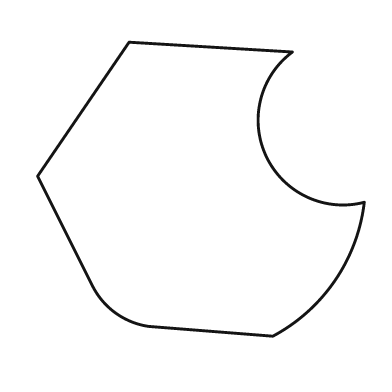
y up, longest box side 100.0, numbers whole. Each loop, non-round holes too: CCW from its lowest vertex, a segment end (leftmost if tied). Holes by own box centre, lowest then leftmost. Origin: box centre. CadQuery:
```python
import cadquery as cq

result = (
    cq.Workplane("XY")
    .moveTo(22.0, -45.0)
    .threePointArc((41.0, -28.0), (50.0, -4.0))
    .threePointArc((20.0, 10.0), (28.0, 42.0))
    .lineTo(-22.0, 45.0)
    .lineTo(-50.0, 4.0)
    .lineTo(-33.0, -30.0)
    .threePointArc((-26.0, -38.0), (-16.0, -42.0))
    .close()
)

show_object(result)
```